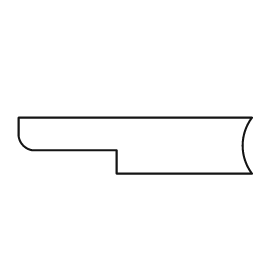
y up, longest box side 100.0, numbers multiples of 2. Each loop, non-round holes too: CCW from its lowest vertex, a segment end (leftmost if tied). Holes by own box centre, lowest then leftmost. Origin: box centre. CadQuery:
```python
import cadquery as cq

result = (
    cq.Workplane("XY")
    .moveTo(-8.0, -12.0)
    .lineTo(50.0, -12.0)
    .threePointArc((46.0, 0.0), (50.0, 12.0))
    .lineTo(-50.0, 12.0)
    .lineTo(-50.0, 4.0)
    .threePointArc((-48.0, 0.0), (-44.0, -2.0))
    .lineTo(-8.0, -2.0)
    .close()
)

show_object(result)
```